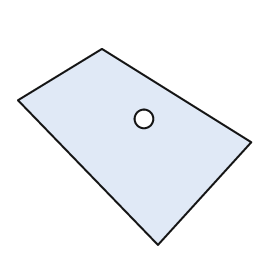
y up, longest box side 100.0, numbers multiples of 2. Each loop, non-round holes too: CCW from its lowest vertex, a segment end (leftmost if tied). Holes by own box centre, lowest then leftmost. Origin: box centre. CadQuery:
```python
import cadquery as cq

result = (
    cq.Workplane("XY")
    .moveTo(10.0, -42.0)
    .lineTo(50.0, 2.0)
    .lineTo(-14.0, 42.0)
    .lineTo(-50.0, 20.0)
    .close()
    .moveTo(4.0, 12.0)
    .circle(4.0)
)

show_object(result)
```